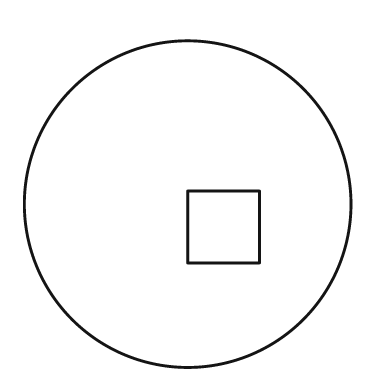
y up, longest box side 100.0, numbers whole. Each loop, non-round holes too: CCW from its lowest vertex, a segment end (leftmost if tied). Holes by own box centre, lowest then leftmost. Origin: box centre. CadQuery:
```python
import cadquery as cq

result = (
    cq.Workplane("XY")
    .moveTo(0.0, 0.0)
    .circle(50.0)
    .moveTo(0.0, -18.0)
    .lineTo(22.0, -18.0)
    .lineTo(22.0, 4.0)
    .lineTo(0.0, 4.0)
    .close()
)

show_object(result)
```